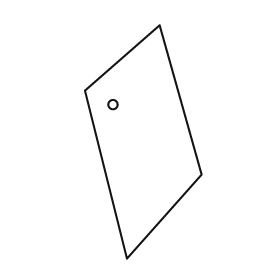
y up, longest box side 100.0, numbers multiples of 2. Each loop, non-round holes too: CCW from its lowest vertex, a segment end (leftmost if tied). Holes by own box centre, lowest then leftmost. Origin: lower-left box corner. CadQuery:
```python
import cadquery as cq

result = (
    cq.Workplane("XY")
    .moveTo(18.0, 0.0)
    .lineTo(50.0, 36.0)
    .lineTo(32.0, 100.0)
    .lineTo(0.0, 72.0)
    .close()
    .moveTo(12.0, 66.0)
    .circle(2.0)
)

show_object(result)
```